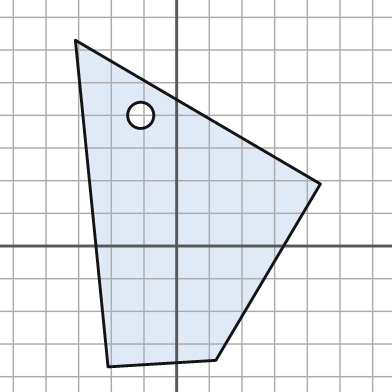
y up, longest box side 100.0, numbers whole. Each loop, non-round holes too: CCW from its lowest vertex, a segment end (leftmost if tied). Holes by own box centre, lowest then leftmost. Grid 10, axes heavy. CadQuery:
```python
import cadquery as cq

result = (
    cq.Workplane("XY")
    .moveTo(-21.0, -37.0)
    .lineTo(12.0, -35.0)
    .lineTo(44.0, 19.0)
    .lineTo(-31.0, 63.0)
    .close()
    .moveTo(-11.0, 40.0)
    .circle(4.0)
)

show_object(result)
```